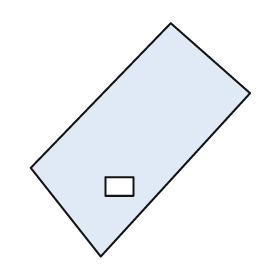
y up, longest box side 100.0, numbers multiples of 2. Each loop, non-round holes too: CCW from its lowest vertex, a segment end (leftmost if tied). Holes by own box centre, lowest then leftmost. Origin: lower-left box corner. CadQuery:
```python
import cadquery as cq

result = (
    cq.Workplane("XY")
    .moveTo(30.0, 0.0)
    .lineTo(94.0, 70.0)
    .lineTo(60.0, 100.0)
    .lineTo(0.0, 38.0)
    .close()
    .moveTo(32.0, 26.0)
    .lineTo(44.0, 26.0)
    .lineTo(44.0, 34.0)
    .lineTo(32.0, 34.0)
    .close()
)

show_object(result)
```